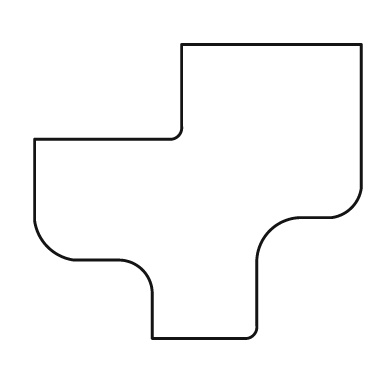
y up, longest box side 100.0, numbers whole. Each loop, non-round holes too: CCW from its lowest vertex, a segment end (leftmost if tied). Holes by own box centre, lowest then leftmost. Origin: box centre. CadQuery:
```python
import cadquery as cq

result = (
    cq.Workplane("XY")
    .moveTo(-14.0, -45.0)
    .lineTo(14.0, -45.0)
    .threePointArc((17.0, -44.0), (18.0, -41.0))
    .lineTo(18.0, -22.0)
    .threePointArc((22.0, -12.0), (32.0, -8.0))
    .lineTo(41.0, -8.0)
    .threePointArc((47.0, -5.0), (50.0, 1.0))
    .lineTo(50.0, 45.0)
    .lineTo(-5.0, 45.0)
    .lineTo(-5.0, 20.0)
    .threePointArc((-6.0, 17.0), (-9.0, 16.0))
    .lineTo(-50.0, 16.0)
    .lineTo(-50.0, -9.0)
    .threePointArc((-46.0, -17.0), (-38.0, -21.0))
    .lineTo(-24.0, -21.0)
    .threePointArc((-17.0, -24.0), (-14.0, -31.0))
    .close()
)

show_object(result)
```